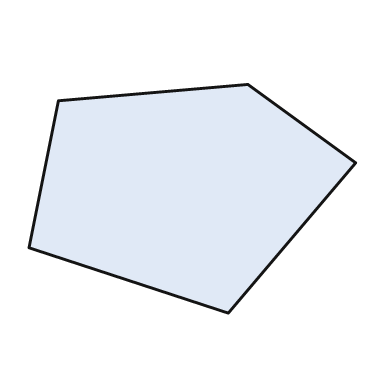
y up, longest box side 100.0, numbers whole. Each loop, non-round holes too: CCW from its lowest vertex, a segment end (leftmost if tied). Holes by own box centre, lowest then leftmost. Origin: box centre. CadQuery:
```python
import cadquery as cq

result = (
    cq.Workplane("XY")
    .moveTo(11.0, -35.0)
    .lineTo(50.0, 11.0)
    .lineTo(17.0, 35.0)
    .lineTo(-41.0, 30.0)
    .lineTo(-50.0, -15.0)
    .close()
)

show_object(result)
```